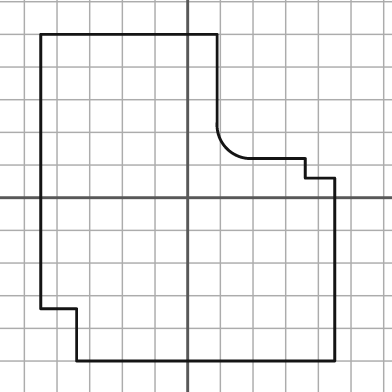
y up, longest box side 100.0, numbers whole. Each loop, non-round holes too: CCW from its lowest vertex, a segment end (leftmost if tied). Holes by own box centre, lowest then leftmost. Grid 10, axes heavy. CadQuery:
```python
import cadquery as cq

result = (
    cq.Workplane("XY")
    .moveTo(-34.0, -50.0)
    .lineTo(45.0, -50.0)
    .lineTo(45.0, 6.0)
    .lineTo(36.0, 6.0)
    .lineTo(36.0, 12.0)
    .lineTo(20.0, 12.0)
    .threePointArc((12.0, 15.0), (9.0, 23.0))
    .lineTo(9.0, 50.0)
    .lineTo(-45.0, 50.0)
    .lineTo(-45.0, -34.0)
    .lineTo(-34.0, -34.0)
    .close()
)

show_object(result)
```